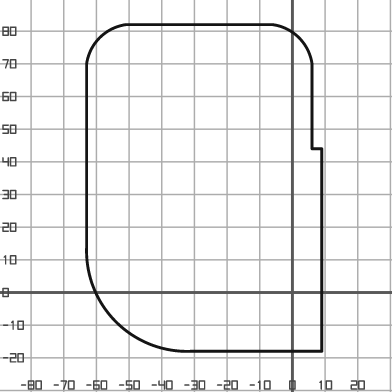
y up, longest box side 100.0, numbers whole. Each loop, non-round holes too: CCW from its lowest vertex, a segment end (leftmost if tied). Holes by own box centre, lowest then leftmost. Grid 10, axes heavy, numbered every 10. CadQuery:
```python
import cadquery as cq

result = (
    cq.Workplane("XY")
    .moveTo(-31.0, -18.0)
    .lineTo(9.0, -18.0)
    .lineTo(9.0, 44.0)
    .lineTo(6.0, 44.0)
    .lineTo(6.0, 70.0)
    .threePointArc((2.0, 78.0), (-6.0, 82.0))
    .lineTo(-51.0, 82.0)
    .threePointArc((-59.0, 78.0), (-63.0, 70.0))
    .lineTo(-63.0, 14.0)
    .threePointArc((-54.0, -9.0), (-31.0, -18.0))
    .close()
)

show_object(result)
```